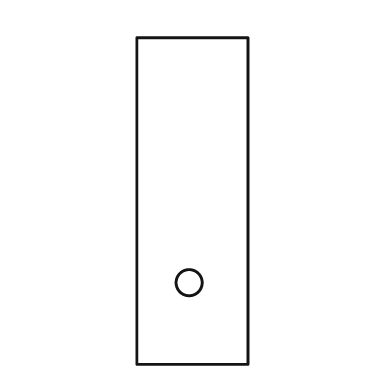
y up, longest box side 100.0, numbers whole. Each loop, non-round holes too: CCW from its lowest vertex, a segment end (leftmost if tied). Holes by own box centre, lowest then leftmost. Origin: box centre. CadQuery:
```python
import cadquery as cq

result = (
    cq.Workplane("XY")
    .moveTo(-17.0, -50.0)
    .lineTo(17.0, -50.0)
    .lineTo(17.0, 50.0)
    .lineTo(-17.0, 50.0)
    .close()
    .moveTo(-1.0, -25.0)
    .circle(4.0)
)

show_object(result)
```